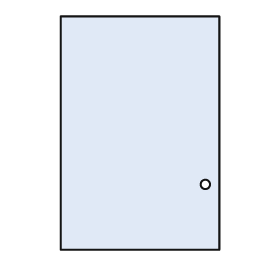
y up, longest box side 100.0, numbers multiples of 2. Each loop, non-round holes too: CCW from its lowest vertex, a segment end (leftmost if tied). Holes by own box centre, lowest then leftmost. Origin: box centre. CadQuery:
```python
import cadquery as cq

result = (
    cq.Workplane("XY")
    .moveTo(-34.0, -50.0)
    .lineTo(34.0, -50.0)
    .lineTo(34.0, 50.0)
    .lineTo(-34.0, 50.0)
    .close()
    .moveTo(28.0, -22.0)
    .circle(2.0)
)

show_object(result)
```